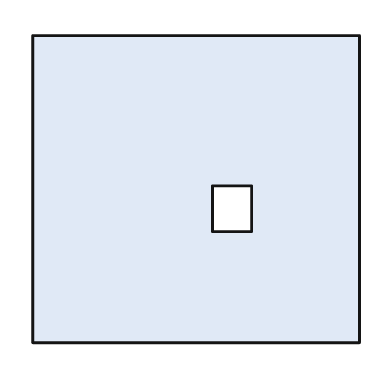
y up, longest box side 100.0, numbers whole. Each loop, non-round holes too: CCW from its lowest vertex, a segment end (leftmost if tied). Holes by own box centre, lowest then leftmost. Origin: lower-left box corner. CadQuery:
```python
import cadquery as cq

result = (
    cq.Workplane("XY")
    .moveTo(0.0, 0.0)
    .lineTo(100.0, 0.0)
    .lineTo(100.0, 94.0)
    .lineTo(0.0, 94.0)
    .close()
    .moveTo(55.0, 34.0)
    .lineTo(67.0, 34.0)
    .lineTo(67.0, 48.0)
    .lineTo(55.0, 48.0)
    .close()
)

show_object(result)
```